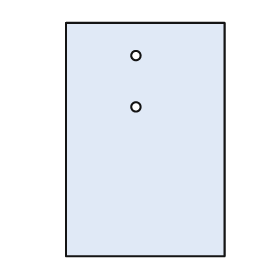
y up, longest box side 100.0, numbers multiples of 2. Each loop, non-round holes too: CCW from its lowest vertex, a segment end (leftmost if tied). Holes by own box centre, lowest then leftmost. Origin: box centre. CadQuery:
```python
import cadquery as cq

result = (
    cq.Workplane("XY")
    .moveTo(-34.0, -50.0)
    .lineTo(34.0, -50.0)
    .lineTo(34.0, 50.0)
    .lineTo(-34.0, 50.0)
    .close()
    .moveTo(-4.0, 14.0)
    .circle(2.0)
    .moveTo(-4.0, 36.0)
    .circle(2.0)
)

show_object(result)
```